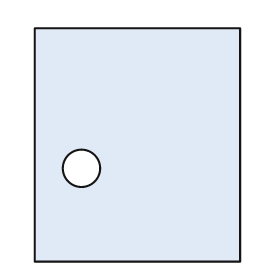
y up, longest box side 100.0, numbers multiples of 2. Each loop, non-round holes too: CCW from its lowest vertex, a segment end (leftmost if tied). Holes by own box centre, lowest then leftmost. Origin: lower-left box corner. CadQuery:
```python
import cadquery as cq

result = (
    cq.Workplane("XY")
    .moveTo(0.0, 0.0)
    .lineTo(88.0, 0.0)
    .lineTo(88.0, 100.0)
    .lineTo(0.0, 100.0)
    .close()
    .moveTo(20.0, 40.0)
    .circle(8.0)
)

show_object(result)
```